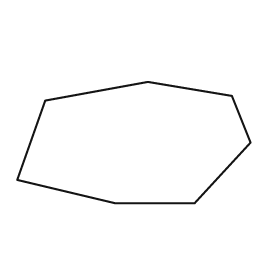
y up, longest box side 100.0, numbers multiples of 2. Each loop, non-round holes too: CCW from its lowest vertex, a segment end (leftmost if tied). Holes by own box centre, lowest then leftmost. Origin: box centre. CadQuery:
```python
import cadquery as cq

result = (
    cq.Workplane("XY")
    .moveTo(-8.0, -26.0)
    .lineTo(26.0, -26.0)
    .lineTo(50.0, 0.0)
    .lineTo(42.0, 20.0)
    .lineTo(6.0, 26.0)
    .lineTo(-38.0, 18.0)
    .lineTo(-50.0, -16.0)
    .close()
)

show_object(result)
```